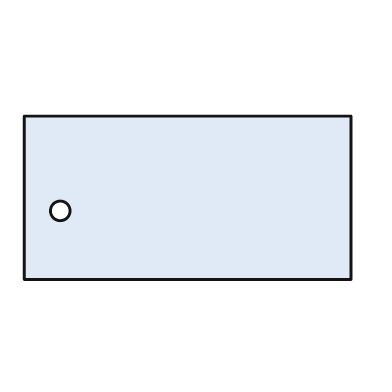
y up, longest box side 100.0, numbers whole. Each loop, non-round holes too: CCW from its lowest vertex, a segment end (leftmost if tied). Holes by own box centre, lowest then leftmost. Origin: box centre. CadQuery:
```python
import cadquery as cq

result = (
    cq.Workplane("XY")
    .moveTo(-50.0, -25.0)
    .lineTo(50.0, -25.0)
    .lineTo(50.0, 25.0)
    .lineTo(-50.0, 25.0)
    .close()
    .moveTo(-39.0, -4.0)
    .circle(3.0)
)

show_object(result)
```